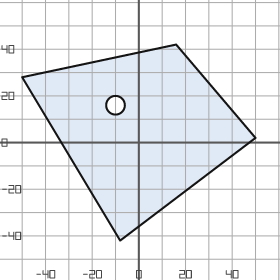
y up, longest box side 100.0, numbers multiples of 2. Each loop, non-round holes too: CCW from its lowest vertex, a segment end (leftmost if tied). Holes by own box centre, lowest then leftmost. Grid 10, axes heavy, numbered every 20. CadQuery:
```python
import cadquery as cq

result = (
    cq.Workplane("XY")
    .moveTo(-8.0, -42.0)
    .lineTo(50.0, 2.0)
    .lineTo(16.0, 42.0)
    .lineTo(-50.0, 28.0)
    .close()
    .moveTo(-10.0, 16.0)
    .circle(4.0)
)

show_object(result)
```